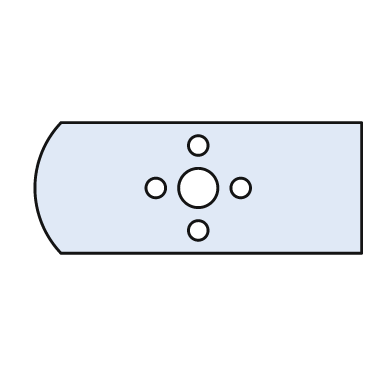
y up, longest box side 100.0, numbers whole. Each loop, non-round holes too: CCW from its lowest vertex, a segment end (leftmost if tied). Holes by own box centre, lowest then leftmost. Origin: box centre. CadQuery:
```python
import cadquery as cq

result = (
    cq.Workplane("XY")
    .moveTo(-42.0, -20.0)
    .lineTo(50.0, -20.0)
    .lineTo(50.0, 20.0)
    .lineTo(-42.0, 20.0)
    .threePointArc((-50.0, 0.0), (-42.0, -20.0))
    .close()
    .moveTo(0.0, -13.0)
    .circle(3.0)
    .moveTo(-13.0, 0.0)
    .circle(3.0)
    .moveTo(0.0, 0.0)
    .circle(6.0)
    .moveTo(13.0, 0.0)
    .circle(3.0)
    .moveTo(0.0, 13.0)
    .circle(3.0)
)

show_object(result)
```